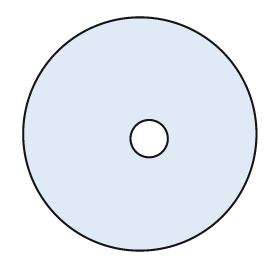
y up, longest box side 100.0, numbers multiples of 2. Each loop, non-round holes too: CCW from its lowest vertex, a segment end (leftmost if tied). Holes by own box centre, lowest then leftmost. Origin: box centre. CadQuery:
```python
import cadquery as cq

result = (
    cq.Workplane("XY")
    .moveTo(0.0, 0.0)
    .circle(50.0)
    .moveTo(4.0, -2.0)
    .circle(8.0)
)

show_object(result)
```